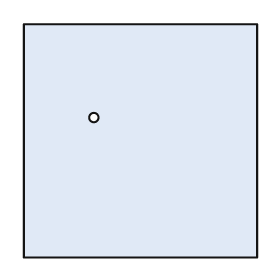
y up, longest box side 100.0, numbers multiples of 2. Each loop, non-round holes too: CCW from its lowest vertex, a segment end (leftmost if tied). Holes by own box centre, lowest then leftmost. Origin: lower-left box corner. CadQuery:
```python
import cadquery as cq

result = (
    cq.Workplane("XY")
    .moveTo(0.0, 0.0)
    .lineTo(100.0, 0.0)
    .lineTo(100.0, 100.0)
    .lineTo(0.0, 100.0)
    .close()
    .moveTo(30.0, 60.0)
    .circle(2.0)
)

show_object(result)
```